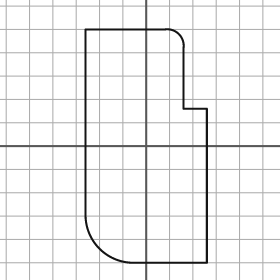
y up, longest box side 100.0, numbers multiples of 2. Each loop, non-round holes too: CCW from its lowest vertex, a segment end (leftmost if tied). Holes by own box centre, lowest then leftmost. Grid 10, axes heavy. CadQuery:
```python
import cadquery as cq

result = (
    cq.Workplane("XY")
    .moveTo(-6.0, -50.0)
    .lineTo(26.0, -50.0)
    .lineTo(26.0, 16.0)
    .lineTo(16.0, 16.0)
    .lineTo(16.0, 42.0)
    .threePointArc((14.0, 48.0), (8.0, 50.0))
    .lineTo(-26.0, 50.0)
    .lineTo(-26.0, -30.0)
    .threePointArc((-20.0, -44.0), (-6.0, -50.0))
    .close()
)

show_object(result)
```